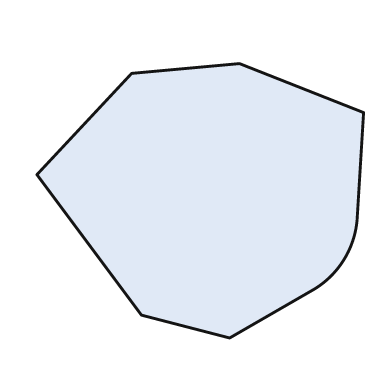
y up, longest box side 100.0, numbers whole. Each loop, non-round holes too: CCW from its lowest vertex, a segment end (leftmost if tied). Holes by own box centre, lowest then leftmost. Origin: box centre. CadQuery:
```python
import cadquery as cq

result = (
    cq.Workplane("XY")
    .moveTo(9.0, -42.0)
    .lineTo(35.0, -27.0)
    .threePointArc((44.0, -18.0), (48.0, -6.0))
    .lineTo(50.0, 27.0)
    .lineTo(12.0, 42.0)
    .lineTo(-21.0, 39.0)
    .lineTo(-50.0, 8.0)
    .lineTo(-18.0, -35.0)
    .close()
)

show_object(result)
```